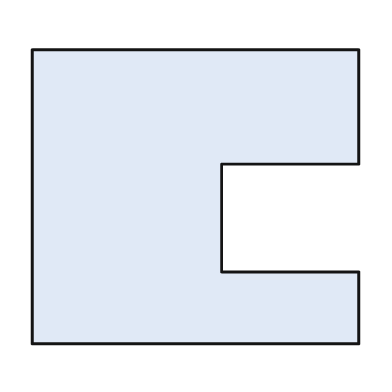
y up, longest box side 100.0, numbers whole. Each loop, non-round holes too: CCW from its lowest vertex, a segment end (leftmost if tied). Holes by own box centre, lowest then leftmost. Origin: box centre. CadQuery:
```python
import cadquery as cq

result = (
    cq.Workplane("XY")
    .moveTo(-50.0, -45.0)
    .lineTo(50.0, -45.0)
    .lineTo(50.0, -23.0)
    .lineTo(8.0, -23.0)
    .lineTo(8.0, 10.0)
    .lineTo(50.0, 10.0)
    .lineTo(50.0, 45.0)
    .lineTo(-50.0, 45.0)
    .close()
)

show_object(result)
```